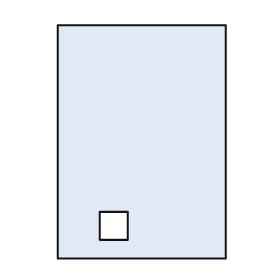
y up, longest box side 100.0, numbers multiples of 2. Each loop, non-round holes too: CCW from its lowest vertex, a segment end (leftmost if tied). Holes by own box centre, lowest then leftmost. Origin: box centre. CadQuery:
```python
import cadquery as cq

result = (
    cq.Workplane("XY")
    .moveTo(-36.0, -50.0)
    .lineTo(36.0, -50.0)
    .lineTo(36.0, 50.0)
    .lineTo(-36.0, 50.0)
    .close()
    .moveTo(-18.0, -42.0)
    .lineTo(-6.0, -42.0)
    .lineTo(-6.0, -30.0)
    .lineTo(-18.0, -30.0)
    .close()
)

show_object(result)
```